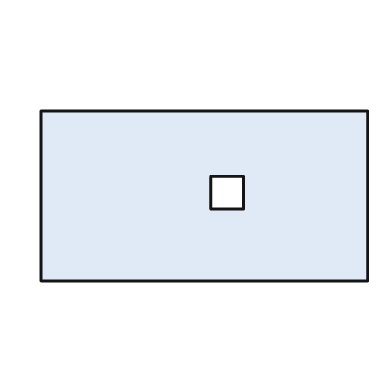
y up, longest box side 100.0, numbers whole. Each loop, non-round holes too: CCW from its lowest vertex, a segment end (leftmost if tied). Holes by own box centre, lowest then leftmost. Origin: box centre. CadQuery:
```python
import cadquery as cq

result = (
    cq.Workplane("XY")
    .moveTo(-50.0, -26.0)
    .lineTo(50.0, -26.0)
    .lineTo(50.0, 26.0)
    .lineTo(-50.0, 26.0)
    .close()
    .moveTo(2.0, -4.0)
    .lineTo(12.0, -4.0)
    .lineTo(12.0, 6.0)
    .lineTo(2.0, 6.0)
    .close()
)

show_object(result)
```